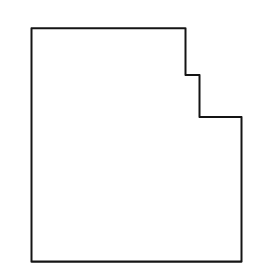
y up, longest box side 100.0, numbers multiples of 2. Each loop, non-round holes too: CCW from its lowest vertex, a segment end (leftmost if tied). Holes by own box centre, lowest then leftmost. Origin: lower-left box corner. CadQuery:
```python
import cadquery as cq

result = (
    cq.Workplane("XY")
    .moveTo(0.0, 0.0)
    .lineTo(90.0, 0.0)
    .lineTo(90.0, 62.0)
    .lineTo(72.0, 62.0)
    .lineTo(72.0, 80.0)
    .lineTo(66.0, 80.0)
    .lineTo(66.0, 100.0)
    .lineTo(0.0, 100.0)
    .close()
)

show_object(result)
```